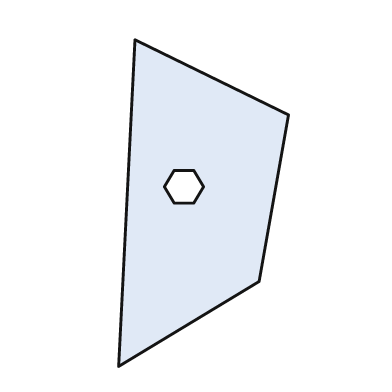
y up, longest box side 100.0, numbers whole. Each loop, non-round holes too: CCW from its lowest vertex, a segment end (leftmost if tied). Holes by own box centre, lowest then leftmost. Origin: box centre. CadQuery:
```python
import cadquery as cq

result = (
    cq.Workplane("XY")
    .moveTo(-26.0, -50.0)
    .lineTo(17.0, -24.0)
    .lineTo(26.0, 27.0)
    .lineTo(-21.0, 50.0)
    .close()
    .moveTo(-9.0, 0.0)
    .lineTo(-3.0, 0.0)
    .lineTo(0.0, 5.0)
    .lineTo(-3.0, 10.0)
    .lineTo(-9.0, 10.0)
    .lineTo(-12.0, 5.0)
    .close()
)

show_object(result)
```